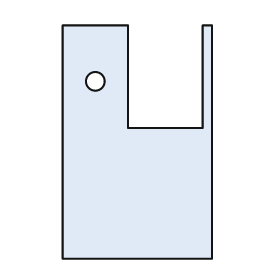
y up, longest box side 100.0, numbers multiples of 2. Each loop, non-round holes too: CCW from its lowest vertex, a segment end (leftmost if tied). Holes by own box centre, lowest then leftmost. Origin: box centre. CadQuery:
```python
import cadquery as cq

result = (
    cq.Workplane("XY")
    .moveTo(-32.0, -50.0)
    .lineTo(32.0, -50.0)
    .lineTo(32.0, 50.0)
    .lineTo(28.0, 50.0)
    .lineTo(28.0, 6.0)
    .lineTo(-4.0, 6.0)
    .lineTo(-4.0, 50.0)
    .lineTo(-32.0, 50.0)
    .close()
    .moveTo(-18.0, 26.0)
    .circle(4.0)
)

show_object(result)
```